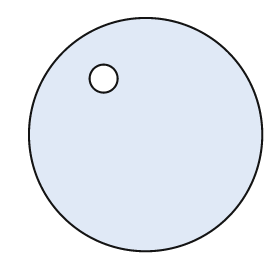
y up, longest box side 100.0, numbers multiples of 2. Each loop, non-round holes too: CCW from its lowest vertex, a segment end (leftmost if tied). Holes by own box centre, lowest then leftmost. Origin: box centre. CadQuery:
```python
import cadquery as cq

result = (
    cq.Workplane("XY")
    .moveTo(0.0, 0.0)
    .circle(50.0)
    .moveTo(-18.0, 24.0)
    .circle(6.0)
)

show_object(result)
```